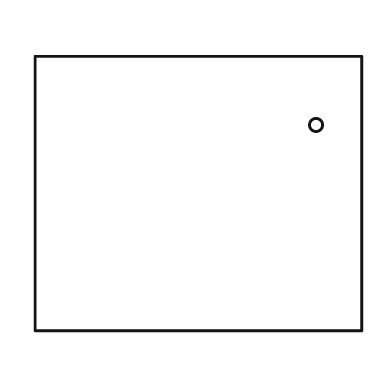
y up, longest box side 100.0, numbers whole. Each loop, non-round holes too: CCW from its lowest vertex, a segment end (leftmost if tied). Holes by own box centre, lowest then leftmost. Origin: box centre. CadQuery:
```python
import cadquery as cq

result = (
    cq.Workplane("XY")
    .moveTo(-50.0, -42.0)
    .lineTo(50.0, -42.0)
    .lineTo(50.0, 42.0)
    .lineTo(-50.0, 42.0)
    .close()
    .moveTo(36.0, 21.0)
    .circle(2.0)
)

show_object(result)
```